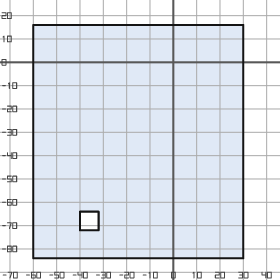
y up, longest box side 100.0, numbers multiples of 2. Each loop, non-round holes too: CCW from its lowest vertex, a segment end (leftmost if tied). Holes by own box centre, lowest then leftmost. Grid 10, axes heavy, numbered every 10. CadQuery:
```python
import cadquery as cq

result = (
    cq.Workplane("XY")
    .moveTo(-60.0, -84.0)
    .lineTo(30.0, -84.0)
    .lineTo(30.0, 16.0)
    .lineTo(-60.0, 16.0)
    .close()
    .moveTo(-40.0, -72.0)
    .lineTo(-32.0, -72.0)
    .lineTo(-32.0, -64.0)
    .lineTo(-40.0, -64.0)
    .close()
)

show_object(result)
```